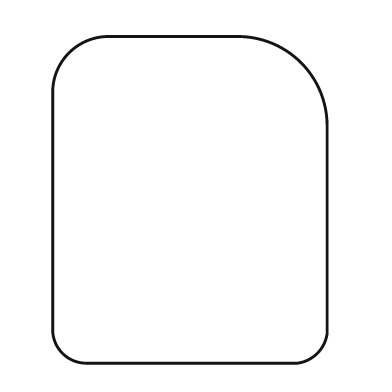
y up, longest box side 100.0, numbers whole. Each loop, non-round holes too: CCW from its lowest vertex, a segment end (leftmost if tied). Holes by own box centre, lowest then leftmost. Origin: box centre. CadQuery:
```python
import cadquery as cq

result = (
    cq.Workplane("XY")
    .moveTo(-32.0, -50.0)
    .lineTo(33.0, -50.0)
    .threePointArc((39.0, -47.0), (42.0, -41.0))
    .lineTo(42.0, 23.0)
    .threePointArc((34.0, 42.0), (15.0, 50.0))
    .lineTo(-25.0, 50.0)
    .threePointArc((-37.0, 45.0), (-42.0, 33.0))
    .lineTo(-42.0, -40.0)
    .threePointArc((-39.0, -47.0), (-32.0, -50.0))
    .close()
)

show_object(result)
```